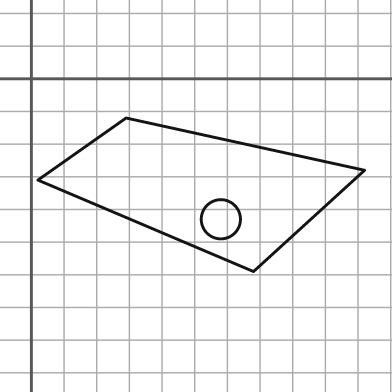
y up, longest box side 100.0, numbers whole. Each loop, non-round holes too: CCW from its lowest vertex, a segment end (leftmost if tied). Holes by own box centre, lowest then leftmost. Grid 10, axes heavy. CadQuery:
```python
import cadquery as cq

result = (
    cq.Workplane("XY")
    .moveTo(68.0, -59.0)
    .lineTo(102.0, -28.0)
    .lineTo(29.0, -12.0)
    .lineTo(2.0, -31.0)
    .close()
    .moveTo(58.0, -43.0)
    .circle(6.0)
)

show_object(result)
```